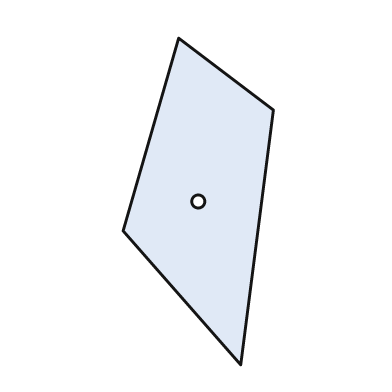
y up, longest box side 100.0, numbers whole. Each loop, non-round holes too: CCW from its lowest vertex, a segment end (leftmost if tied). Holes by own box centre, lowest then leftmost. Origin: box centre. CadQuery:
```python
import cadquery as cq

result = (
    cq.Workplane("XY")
    .moveTo(13.0, -50.0)
    .lineTo(23.0, 28.0)
    .lineTo(-6.0, 50.0)
    .lineTo(-23.0, -9.0)
    .close()
    .moveTo(0.0, 0.0)
    .circle(2.0)
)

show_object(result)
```